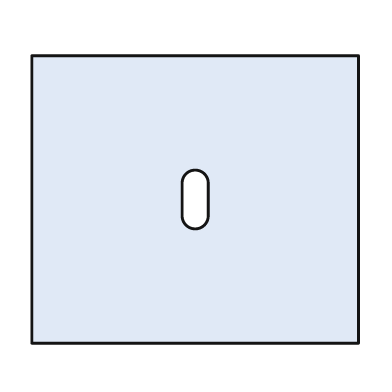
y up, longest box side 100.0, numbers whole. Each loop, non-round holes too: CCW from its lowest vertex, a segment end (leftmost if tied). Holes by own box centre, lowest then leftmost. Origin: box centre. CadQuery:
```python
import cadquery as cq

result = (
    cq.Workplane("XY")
    .moveTo(-50.0, -44.0)
    .lineTo(50.0, -44.0)
    .lineTo(50.0, 44.0)
    .lineTo(-50.0, 44.0)
    .close()
    .moveTo(-4.0, -5.0)
    .threePointArc((0.0, -9.0), (4.0, -5.0))
    .lineTo(4.0, 5.0)
    .threePointArc((0.0, 9.0), (-4.0, 5.0))
    .close()
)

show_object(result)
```